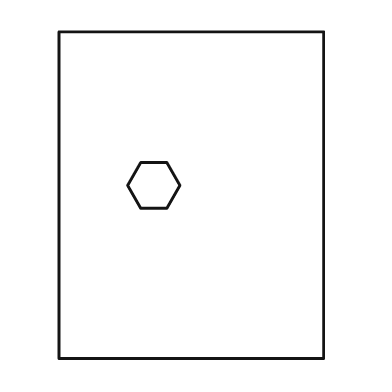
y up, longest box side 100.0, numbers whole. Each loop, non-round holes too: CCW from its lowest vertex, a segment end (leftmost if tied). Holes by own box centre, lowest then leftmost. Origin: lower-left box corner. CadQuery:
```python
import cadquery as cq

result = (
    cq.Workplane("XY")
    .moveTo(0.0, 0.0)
    .lineTo(81.0, 0.0)
    .lineTo(81.0, 100.0)
    .lineTo(0.0, 100.0)
    .close()
    .moveTo(25.0, 46.0)
    .lineTo(33.0, 46.0)
    .lineTo(37.0, 53.0)
    .lineTo(33.0, 60.0)
    .lineTo(25.0, 60.0)
    .lineTo(21.0, 53.0)
    .close()
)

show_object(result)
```